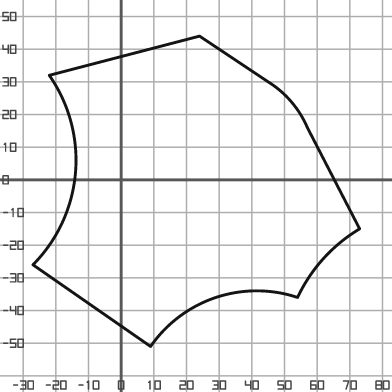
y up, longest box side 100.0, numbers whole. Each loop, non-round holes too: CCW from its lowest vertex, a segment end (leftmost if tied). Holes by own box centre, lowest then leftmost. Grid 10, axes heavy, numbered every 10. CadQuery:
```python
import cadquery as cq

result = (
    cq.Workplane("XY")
    .moveTo(9.0, -51.0)
    .threePointArc((29.0, -36.0), (54.0, -36.0))
    .threePointArc((62.0, -24.0), (73.0, -15.0))
    .lineTo(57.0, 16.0)
    .threePointArc((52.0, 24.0), (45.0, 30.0))
    .lineTo(24.0, 44.0)
    .lineTo(-22.0, 32.0)
    .threePointArc((-14.0, 2.0), (-27.0, -26.0))
    .close()
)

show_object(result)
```